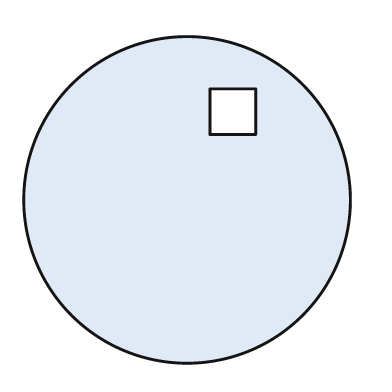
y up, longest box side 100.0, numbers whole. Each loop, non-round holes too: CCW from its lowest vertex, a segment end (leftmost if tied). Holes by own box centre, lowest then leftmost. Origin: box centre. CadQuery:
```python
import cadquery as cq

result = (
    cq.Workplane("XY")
    .moveTo(0.0, 0.0)
    .circle(50.0)
    .moveTo(7.0, 20.0)
    .lineTo(21.0, 20.0)
    .lineTo(21.0, 34.0)
    .lineTo(7.0, 34.0)
    .close()
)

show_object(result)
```